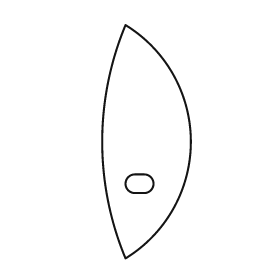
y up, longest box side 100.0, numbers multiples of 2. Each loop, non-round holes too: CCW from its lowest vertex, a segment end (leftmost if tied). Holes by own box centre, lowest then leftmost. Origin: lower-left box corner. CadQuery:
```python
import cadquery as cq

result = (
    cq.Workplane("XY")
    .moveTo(10.0, 0.0)
    .threePointArc((38.0, 50.0), (10.0, 100.0))
    .threePointArc((0.0, 50.0), (10.0, 0.0))
    .close()
    .moveTo(14.0, 28.0)
    .lineTo(18.0, 28.0)
    .threePointArc((22.0, 32.0), (18.0, 36.0))
    .lineTo(14.0, 36.0)
    .threePointArc((10.0, 32.0), (14.0, 28.0))
    .close()
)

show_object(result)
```